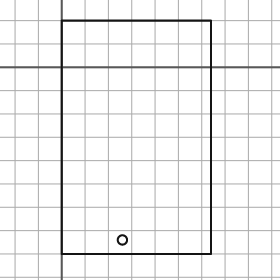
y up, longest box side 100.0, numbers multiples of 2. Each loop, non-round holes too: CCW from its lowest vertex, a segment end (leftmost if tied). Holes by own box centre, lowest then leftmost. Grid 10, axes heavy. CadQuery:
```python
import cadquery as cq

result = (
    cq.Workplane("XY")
    .moveTo(0.0, -80.0)
    .lineTo(64.0, -80.0)
    .lineTo(64.0, 20.0)
    .lineTo(0.0, 20.0)
    .close()
    .moveTo(26.0, -74.0)
    .circle(2.0)
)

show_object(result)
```